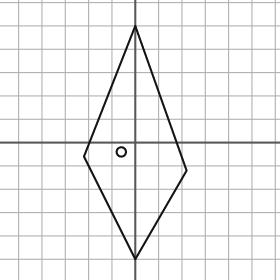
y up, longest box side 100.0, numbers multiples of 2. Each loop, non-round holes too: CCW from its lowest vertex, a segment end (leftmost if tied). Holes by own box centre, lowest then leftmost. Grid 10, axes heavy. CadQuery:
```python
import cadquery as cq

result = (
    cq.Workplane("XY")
    .moveTo(0.0, -50.0)
    .lineTo(22.0, -12.0)
    .lineTo(0.0, 50.0)
    .lineTo(-22.0, -6.0)
    .close()
    .moveTo(-6.0, -4.0)
    .circle(2.0)
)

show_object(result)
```